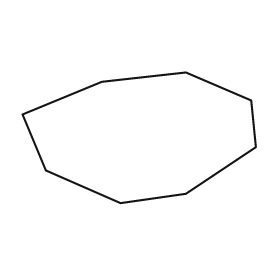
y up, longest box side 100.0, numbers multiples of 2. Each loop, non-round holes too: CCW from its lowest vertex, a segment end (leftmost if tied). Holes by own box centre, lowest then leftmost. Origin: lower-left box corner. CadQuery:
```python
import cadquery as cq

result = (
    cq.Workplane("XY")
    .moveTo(42.0, 0.0)
    .lineTo(70.0, 4.0)
    .lineTo(100.0, 24.0)
    .lineTo(98.0, 44.0)
    .lineTo(70.0, 56.0)
    .lineTo(34.0, 52.0)
    .lineTo(0.0, 38.0)
    .lineTo(10.0, 14.0)
    .close()
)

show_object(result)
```